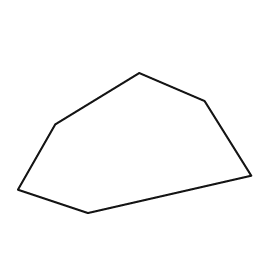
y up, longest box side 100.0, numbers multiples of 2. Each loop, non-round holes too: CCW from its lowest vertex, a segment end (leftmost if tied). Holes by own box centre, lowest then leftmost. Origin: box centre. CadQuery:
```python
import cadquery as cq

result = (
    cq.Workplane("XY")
    .moveTo(-20.0, -30.0)
    .lineTo(50.0, -14.0)
    .lineTo(30.0, 18.0)
    .lineTo(2.0, 30.0)
    .lineTo(-34.0, 8.0)
    .lineTo(-50.0, -20.0)
    .close()
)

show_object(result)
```